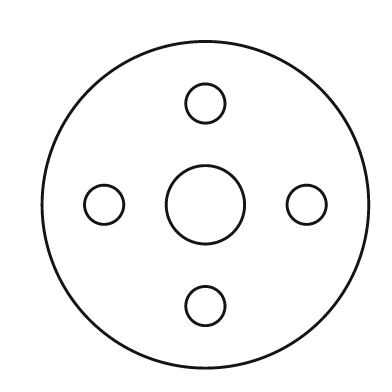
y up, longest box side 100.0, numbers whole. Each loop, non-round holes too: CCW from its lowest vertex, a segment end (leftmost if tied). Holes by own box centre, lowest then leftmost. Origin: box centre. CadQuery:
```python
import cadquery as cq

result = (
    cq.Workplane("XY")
    .moveTo(0.0, 0.0)
    .circle(50.0)
    .moveTo(0.0, -31.0)
    .circle(6.0)
    .moveTo(-31.0, 0.0)
    .circle(6.0)
    .moveTo(0.0, 0.0)
    .circle(12.0)
    .moveTo(31.0, 0.0)
    .circle(6.0)
    .moveTo(0.0, 31.0)
    .circle(6.0)
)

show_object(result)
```